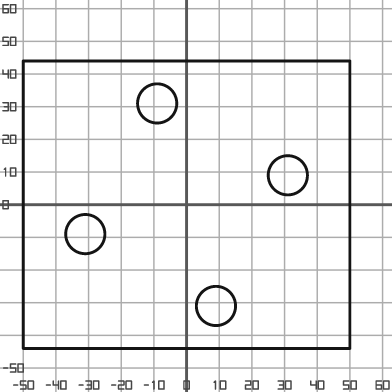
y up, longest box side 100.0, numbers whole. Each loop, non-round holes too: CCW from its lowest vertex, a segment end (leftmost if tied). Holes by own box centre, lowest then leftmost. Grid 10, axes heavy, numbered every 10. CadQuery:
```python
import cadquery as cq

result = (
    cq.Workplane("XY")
    .moveTo(-50.0, -44.0)
    .lineTo(50.0, -44.0)
    .lineTo(50.0, 44.0)
    .lineTo(-50.0, 44.0)
    .close()
    .moveTo(9.0, -31.0)
    .circle(6.0)
    .moveTo(-31.0, -9.0)
    .circle(6.0)
    .moveTo(31.0, 9.0)
    .circle(6.0)
    .moveTo(-9.0, 31.0)
    .circle(6.0)
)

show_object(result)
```